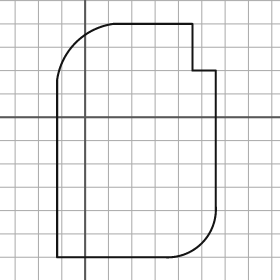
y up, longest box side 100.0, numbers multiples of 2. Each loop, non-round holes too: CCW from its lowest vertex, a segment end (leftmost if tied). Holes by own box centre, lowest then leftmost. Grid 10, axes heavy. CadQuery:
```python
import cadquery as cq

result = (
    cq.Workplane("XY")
    .moveTo(-12.0, -60.0)
    .lineTo(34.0, -60.0)
    .threePointArc((50.0, -54.0), (56.0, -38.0))
    .lineTo(56.0, 20.0)
    .lineTo(46.0, 20.0)
    .lineTo(46.0, 40.0)
    .lineTo(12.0, 40.0)
    .threePointArc((-4.0, 32.0), (-12.0, 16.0))
    .close()
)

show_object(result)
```